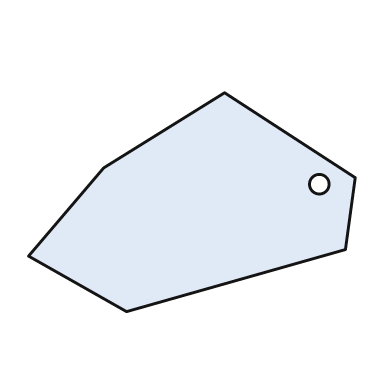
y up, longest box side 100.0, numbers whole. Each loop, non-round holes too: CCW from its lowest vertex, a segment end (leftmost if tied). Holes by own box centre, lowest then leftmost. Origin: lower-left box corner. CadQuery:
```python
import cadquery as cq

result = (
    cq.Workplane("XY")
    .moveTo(30.0, 0.0)
    .lineTo(97.0, 19.0)
    .lineTo(100.0, 41.0)
    .lineTo(60.0, 67.0)
    .lineTo(23.0, 44.0)
    .lineTo(0.0, 17.0)
    .close()
    .moveTo(89.0, 39.0)
    .circle(3.0)
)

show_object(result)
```